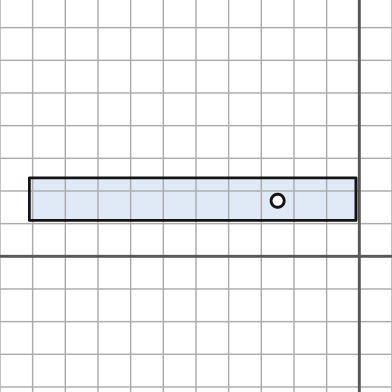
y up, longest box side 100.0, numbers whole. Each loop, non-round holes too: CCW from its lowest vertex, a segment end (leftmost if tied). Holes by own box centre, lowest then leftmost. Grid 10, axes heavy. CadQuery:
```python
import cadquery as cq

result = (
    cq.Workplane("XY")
    .moveTo(-101.0, 11.0)
    .lineTo(-1.0, 11.0)
    .lineTo(-1.0, 24.0)
    .lineTo(-101.0, 24.0)
    .close()
    .moveTo(-25.0, 17.0)
    .circle(2.0)
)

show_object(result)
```